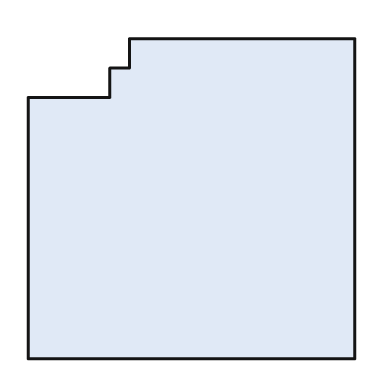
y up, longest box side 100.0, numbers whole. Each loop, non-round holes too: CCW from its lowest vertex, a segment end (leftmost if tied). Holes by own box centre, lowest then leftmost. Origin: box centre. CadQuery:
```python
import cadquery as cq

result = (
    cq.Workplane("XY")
    .moveTo(-50.0, -49.0)
    .lineTo(50.0, -49.0)
    .lineTo(50.0, 49.0)
    .lineTo(-19.0, 49.0)
    .lineTo(-19.0, 40.0)
    .lineTo(-25.0, 40.0)
    .lineTo(-25.0, 31.0)
    .lineTo(-50.0, 31.0)
    .close()
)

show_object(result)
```